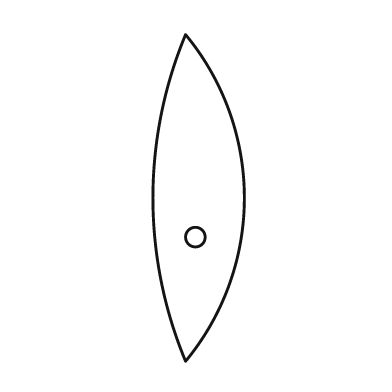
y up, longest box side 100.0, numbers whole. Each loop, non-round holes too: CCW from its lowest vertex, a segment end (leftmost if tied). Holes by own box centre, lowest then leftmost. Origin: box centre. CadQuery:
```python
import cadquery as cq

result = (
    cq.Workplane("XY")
    .moveTo(-4.0, -50.0)
    .threePointArc((14.0, 0.0), (-4.0, 50.0))
    .threePointArc((-14.0, 0.0), (-4.0, -50.0))
    .close()
    .moveTo(-1.0, -12.0)
    .circle(3.0)
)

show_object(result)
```